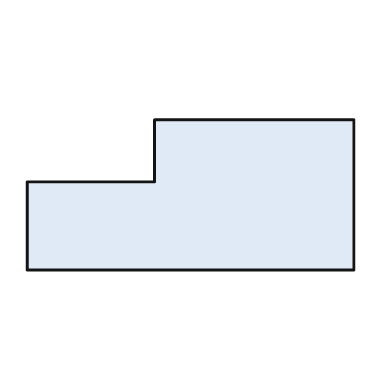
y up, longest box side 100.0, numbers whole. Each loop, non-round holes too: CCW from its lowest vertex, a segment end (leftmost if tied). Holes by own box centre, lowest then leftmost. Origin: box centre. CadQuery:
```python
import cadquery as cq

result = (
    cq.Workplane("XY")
    .moveTo(-50.0, -23.0)
    .lineTo(50.0, -23.0)
    .lineTo(50.0, 23.0)
    .lineTo(-11.0, 23.0)
    .lineTo(-11.0, 4.0)
    .lineTo(-50.0, 4.0)
    .close()
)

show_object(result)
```